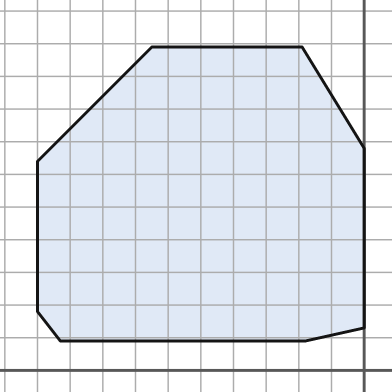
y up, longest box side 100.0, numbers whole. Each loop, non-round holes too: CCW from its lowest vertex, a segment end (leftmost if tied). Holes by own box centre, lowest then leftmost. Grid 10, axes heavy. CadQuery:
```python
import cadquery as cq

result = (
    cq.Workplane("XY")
    .moveTo(-93.0, 9.0)
    .lineTo(-18.0, 9.0)
    .lineTo(0.0, 13.0)
    .lineTo(0.0, 68.0)
    .lineTo(-19.0, 99.0)
    .lineTo(-65.0, 99.0)
    .lineTo(-100.0, 64.0)
    .lineTo(-100.0, 18.0)
    .close()
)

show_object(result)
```